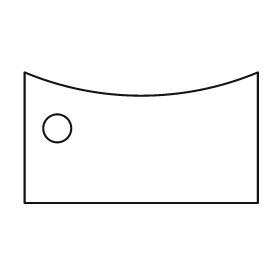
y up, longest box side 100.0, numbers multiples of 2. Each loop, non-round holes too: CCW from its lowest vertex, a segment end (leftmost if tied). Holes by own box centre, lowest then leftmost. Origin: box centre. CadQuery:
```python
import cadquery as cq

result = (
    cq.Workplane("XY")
    .moveTo(-50.0, -28.0)
    .lineTo(50.0, -28.0)
    .lineTo(50.0, 28.0)
    .threePointArc((0.0, 18.0), (-50.0, 28.0))
    .close()
    .moveTo(-36.0, 4.0)
    .circle(6.0)
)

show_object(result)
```